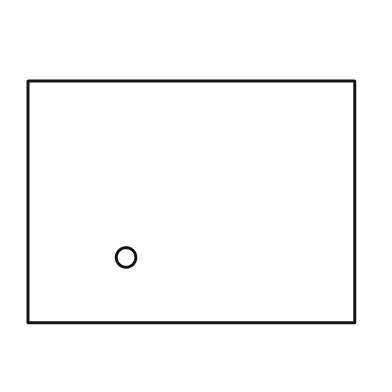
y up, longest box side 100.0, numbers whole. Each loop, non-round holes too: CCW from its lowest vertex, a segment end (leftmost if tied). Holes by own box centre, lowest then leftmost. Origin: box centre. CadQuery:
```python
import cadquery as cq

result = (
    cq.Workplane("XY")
    .moveTo(-50.0, -37.0)
    .lineTo(50.0, -37.0)
    .lineTo(50.0, 37.0)
    .lineTo(-50.0, 37.0)
    .close()
    .moveTo(-20.0, -17.0)
    .circle(3.0)
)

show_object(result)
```